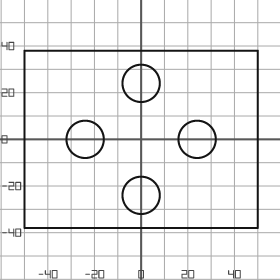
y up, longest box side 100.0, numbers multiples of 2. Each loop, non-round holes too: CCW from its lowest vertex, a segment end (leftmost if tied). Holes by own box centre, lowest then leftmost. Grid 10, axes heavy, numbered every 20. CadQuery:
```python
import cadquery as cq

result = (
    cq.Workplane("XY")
    .moveTo(-50.0, -38.0)
    .lineTo(50.0, -38.0)
    .lineTo(50.0, 38.0)
    .lineTo(-50.0, 38.0)
    .close()
    .moveTo(0.0, -24.0)
    .circle(8.0)
    .moveTo(-24.0, 0.0)
    .circle(8.0)
    .moveTo(24.0, 0.0)
    .circle(8.0)
    .moveTo(0.0, 24.0)
    .circle(8.0)
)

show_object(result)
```